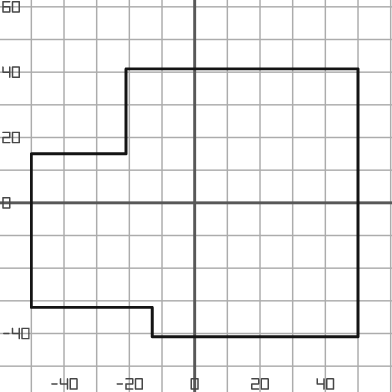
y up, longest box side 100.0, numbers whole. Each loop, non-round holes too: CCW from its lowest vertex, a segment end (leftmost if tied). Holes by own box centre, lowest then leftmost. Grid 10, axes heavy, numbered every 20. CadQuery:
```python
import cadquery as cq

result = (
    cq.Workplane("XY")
    .moveTo(-13.0, -41.0)
    .lineTo(50.0, -41.0)
    .lineTo(50.0, 41.0)
    .lineTo(-21.0, 41.0)
    .lineTo(-21.0, 15.0)
    .lineTo(-50.0, 15.0)
    .lineTo(-50.0, -32.0)
    .lineTo(-13.0, -32.0)
    .close()
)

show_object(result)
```